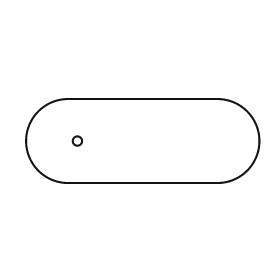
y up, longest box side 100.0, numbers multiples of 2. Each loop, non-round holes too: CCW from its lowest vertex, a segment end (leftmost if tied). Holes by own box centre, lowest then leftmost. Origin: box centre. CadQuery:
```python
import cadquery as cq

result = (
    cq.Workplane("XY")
    .moveTo(-32.0, -18.0)
    .lineTo(32.0, -18.0)
    .threePointArc((50.0, 0.0), (32.0, 18.0))
    .lineTo(-32.0, 18.0)
    .threePointArc((-50.0, 0.0), (-32.0, -18.0))
    .close()
    .moveTo(-28.0, 0.0)
    .circle(2.0)
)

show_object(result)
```